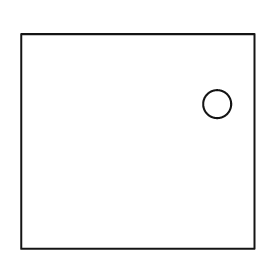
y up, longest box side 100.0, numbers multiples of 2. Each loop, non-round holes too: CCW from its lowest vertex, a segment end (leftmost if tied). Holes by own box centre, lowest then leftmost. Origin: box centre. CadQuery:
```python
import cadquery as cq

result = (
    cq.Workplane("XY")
    .moveTo(-50.0, -46.0)
    .lineTo(50.0, -46.0)
    .lineTo(50.0, 46.0)
    .lineTo(-50.0, 46.0)
    .close()
    .moveTo(34.0, 16.0)
    .circle(6.0)
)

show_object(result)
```